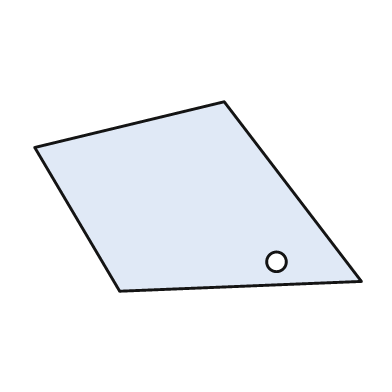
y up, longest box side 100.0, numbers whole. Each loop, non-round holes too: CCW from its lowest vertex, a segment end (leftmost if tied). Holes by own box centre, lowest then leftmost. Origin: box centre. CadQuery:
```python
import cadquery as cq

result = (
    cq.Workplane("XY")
    .moveTo(-24.0, -29.0)
    .lineTo(50.0, -26.0)
    .lineTo(8.0, 29.0)
    .lineTo(-50.0, 15.0)
    .close()
    .moveTo(24.0, -20.0)
    .circle(3.0)
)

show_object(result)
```